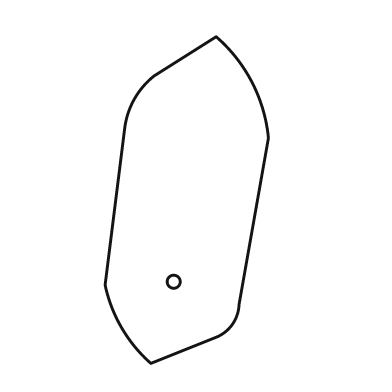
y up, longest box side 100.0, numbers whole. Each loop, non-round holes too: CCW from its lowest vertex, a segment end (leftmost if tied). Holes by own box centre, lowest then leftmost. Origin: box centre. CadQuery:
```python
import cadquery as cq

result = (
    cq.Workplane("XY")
    .moveTo(-11.0, -50.0)
    .lineTo(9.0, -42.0)
    .threePointArc((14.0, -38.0), (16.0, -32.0))
    .lineTo(25.0, 19.0)
    .threePointArc((20.0, 36.0), (9.0, 50.0))
    .lineTo(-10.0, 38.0)
    .threePointArc((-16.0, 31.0), (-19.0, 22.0))
    .lineTo(-25.0, -26.0)
    .threePointArc((-20.0, -39.0), (-11.0, -50.0))
    .close()
    .moveTo(-4.0, -25.0)
    .circle(2.0)
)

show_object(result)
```